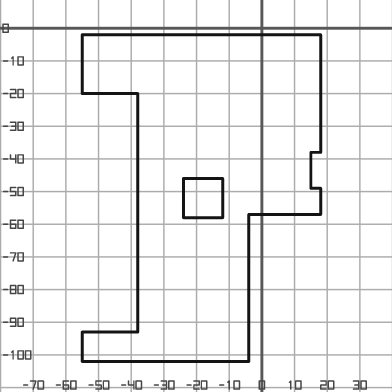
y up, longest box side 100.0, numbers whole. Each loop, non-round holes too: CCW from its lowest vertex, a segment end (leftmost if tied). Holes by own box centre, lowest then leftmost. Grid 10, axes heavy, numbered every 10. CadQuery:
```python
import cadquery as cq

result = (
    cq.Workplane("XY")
    .moveTo(-55.0, -102.0)
    .lineTo(-4.0, -102.0)
    .lineTo(-4.0, -57.0)
    .lineTo(18.0, -57.0)
    .lineTo(18.0, -49.0)
    .lineTo(15.0, -49.0)
    .lineTo(15.0, -38.0)
    .lineTo(18.0, -38.0)
    .lineTo(18.0, -2.0)
    .lineTo(-55.0, -2.0)
    .lineTo(-55.0, -20.0)
    .lineTo(-38.0, -20.0)
    .lineTo(-38.0, -93.0)
    .lineTo(-55.0, -93.0)
    .close()
    .moveTo(-24.0, -58.0)
    .lineTo(-12.0, -58.0)
    .lineTo(-12.0, -46.0)
    .lineTo(-24.0, -46.0)
    .close()
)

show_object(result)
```